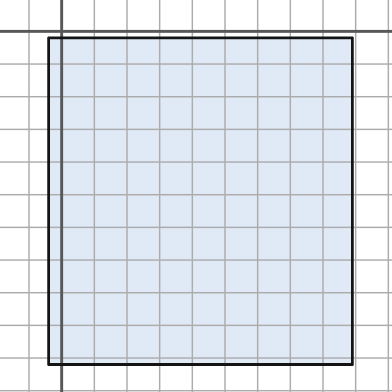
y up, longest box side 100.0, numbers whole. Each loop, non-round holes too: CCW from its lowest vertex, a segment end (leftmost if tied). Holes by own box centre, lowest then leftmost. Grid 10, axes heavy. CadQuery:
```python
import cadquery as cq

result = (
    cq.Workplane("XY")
    .moveTo(-4.0, -102.0)
    .lineTo(89.0, -102.0)
    .lineTo(89.0, -2.0)
    .lineTo(-4.0, -2.0)
    .close()
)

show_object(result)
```